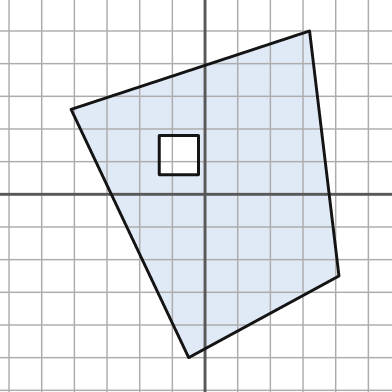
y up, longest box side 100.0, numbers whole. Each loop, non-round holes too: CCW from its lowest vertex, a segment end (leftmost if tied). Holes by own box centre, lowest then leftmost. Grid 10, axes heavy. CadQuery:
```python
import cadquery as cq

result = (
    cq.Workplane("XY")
    .moveTo(-5.0, -50.0)
    .lineTo(41.0, -25.0)
    .lineTo(32.0, 50.0)
    .lineTo(-41.0, 26.0)
    .close()
    .moveTo(-14.0, 6.0)
    .lineTo(-2.0, 6.0)
    .lineTo(-2.0, 18.0)
    .lineTo(-14.0, 18.0)
    .close()
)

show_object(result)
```